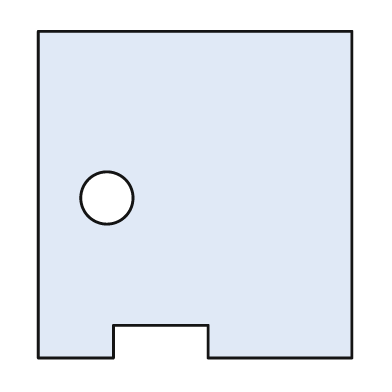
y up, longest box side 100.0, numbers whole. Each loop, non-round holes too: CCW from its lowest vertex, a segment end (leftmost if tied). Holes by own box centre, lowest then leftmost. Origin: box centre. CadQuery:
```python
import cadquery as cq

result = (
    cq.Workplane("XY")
    .moveTo(-48.0, -50.0)
    .lineTo(-25.0, -50.0)
    .lineTo(-25.0, -40.0)
    .lineTo(4.0, -40.0)
    .lineTo(4.0, -50.0)
    .lineTo(48.0, -50.0)
    .lineTo(48.0, 50.0)
    .lineTo(-48.0, 50.0)
    .close()
    .moveTo(-27.0, -1.0)
    .circle(8.0)
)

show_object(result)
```